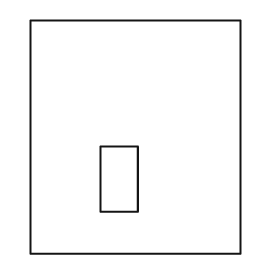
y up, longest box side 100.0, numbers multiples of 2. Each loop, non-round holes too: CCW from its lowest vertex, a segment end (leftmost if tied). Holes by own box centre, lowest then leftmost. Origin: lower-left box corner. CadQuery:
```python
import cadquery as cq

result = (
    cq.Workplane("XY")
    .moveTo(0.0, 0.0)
    .lineTo(90.0, 0.0)
    .lineTo(90.0, 100.0)
    .lineTo(0.0, 100.0)
    .close()
    .moveTo(30.0, 18.0)
    .lineTo(46.0, 18.0)
    .lineTo(46.0, 46.0)
    .lineTo(30.0, 46.0)
    .close()
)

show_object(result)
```